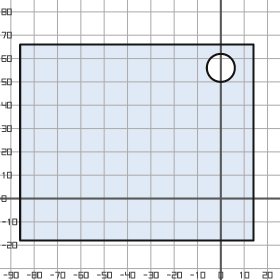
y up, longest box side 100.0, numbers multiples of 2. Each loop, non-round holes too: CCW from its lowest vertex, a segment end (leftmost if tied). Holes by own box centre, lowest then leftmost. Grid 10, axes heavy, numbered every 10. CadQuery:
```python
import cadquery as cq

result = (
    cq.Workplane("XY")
    .moveTo(-86.0, -18.0)
    .lineTo(14.0, -18.0)
    .lineTo(14.0, 66.0)
    .lineTo(-86.0, 66.0)
    .close()
    .moveTo(0.0, 56.0)
    .circle(6.0)
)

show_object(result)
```